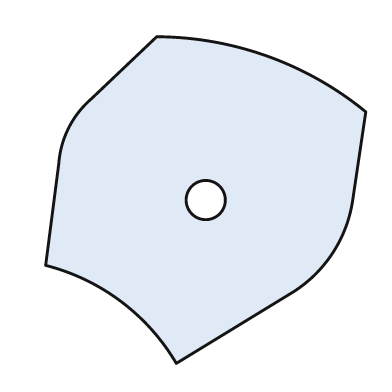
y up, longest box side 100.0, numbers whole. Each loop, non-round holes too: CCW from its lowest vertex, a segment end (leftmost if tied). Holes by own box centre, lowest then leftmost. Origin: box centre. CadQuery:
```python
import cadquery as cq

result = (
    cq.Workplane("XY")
    .moveTo(-9.0, -50.0)
    .lineTo(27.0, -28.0)
    .threePointArc((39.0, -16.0), (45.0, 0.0))
    .lineTo(49.0, 27.0)
    .threePointArc((19.0, 44.0), (-15.0, 50.0))
    .lineTo(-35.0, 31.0)
    .threePointArc((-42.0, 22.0), (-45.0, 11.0))
    .lineTo(-49.0, -20.0)
    .threePointArc((-26.0, -31.0), (-9.0, -50.0))
    .close()
    .moveTo(0.0, 0.0)
    .circle(6.0)
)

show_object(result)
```